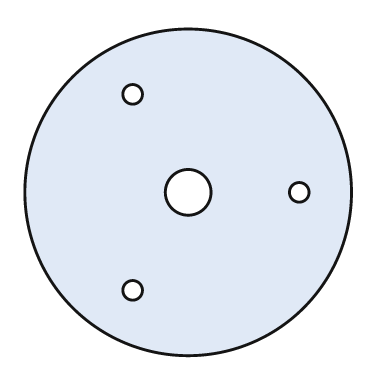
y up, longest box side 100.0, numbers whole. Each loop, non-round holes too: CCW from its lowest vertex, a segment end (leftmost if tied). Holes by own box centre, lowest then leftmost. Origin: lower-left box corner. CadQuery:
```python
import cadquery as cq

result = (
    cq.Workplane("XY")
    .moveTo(50.0, 50.0)
    .circle(50.0)
    .moveTo(33.0, 20.0)
    .circle(3.0)
    .moveTo(50.0, 50.0)
    .circle(7.0)
    .moveTo(84.0, 50.0)
    .circle(3.0)
    .moveTo(33.0, 80.0)
    .circle(3.0)
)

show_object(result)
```